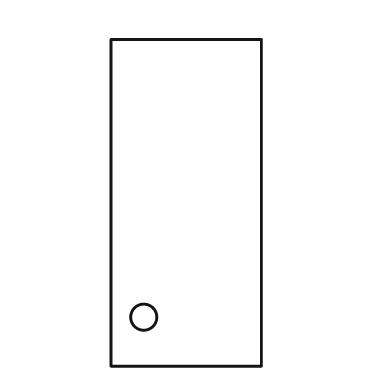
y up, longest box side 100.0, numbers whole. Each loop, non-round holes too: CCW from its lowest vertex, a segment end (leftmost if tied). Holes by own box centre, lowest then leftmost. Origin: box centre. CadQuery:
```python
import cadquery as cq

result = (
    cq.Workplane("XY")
    .moveTo(-23.0, -50.0)
    .lineTo(23.0, -50.0)
    .lineTo(23.0, 50.0)
    .lineTo(-23.0, 50.0)
    .close()
    .moveTo(-13.0, -35.0)
    .circle(4.0)
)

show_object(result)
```